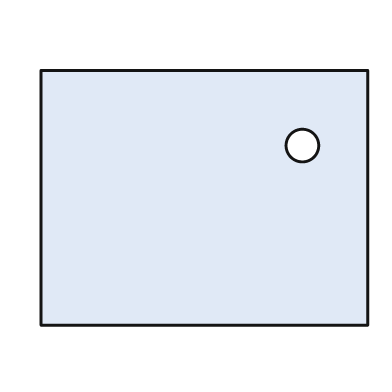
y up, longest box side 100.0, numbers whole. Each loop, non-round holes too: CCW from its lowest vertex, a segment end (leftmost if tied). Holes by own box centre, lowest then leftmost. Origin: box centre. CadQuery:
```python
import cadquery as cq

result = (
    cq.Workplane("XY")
    .moveTo(-50.0, -39.0)
    .lineTo(50.0, -39.0)
    .lineTo(50.0, 39.0)
    .lineTo(-50.0, 39.0)
    .close()
    .moveTo(30.0, 16.0)
    .circle(5.0)
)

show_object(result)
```